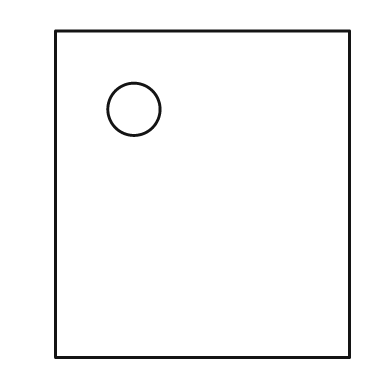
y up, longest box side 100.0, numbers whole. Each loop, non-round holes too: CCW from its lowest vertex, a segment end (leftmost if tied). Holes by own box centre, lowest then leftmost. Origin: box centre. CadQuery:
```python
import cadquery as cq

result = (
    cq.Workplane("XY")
    .moveTo(-45.0, -50.0)
    .lineTo(45.0, -50.0)
    .lineTo(45.0, 50.0)
    .lineTo(-45.0, 50.0)
    .close()
    .moveTo(-21.0, 26.0)
    .circle(8.0)
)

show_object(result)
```